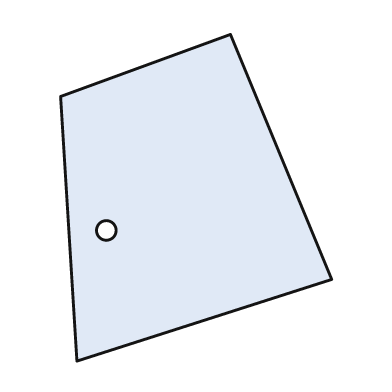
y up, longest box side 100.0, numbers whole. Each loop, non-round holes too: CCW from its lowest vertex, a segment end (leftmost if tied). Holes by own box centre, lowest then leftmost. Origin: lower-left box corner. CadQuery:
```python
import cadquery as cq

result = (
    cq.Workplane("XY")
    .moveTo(5.0, 0.0)
    .lineTo(83.0, 25.0)
    .lineTo(52.0, 100.0)
    .lineTo(0.0, 81.0)
    .close()
    .moveTo(14.0, 40.0)
    .circle(3.0)
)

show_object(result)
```